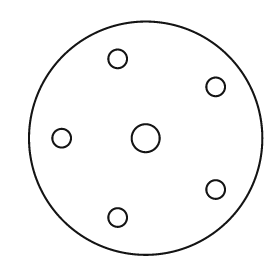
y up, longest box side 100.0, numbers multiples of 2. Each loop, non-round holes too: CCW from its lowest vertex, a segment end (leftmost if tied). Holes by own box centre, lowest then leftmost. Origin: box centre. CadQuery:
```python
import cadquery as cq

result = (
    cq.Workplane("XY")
    .moveTo(0.0, 0.0)
    .circle(50.0)
    .moveTo(-12.0, -34.0)
    .circle(4.0)
    .moveTo(30.0, -22.0)
    .circle(4.0)
    .moveTo(-36.0, 0.0)
    .circle(4.0)
    .moveTo(0.0, 0.0)
    .circle(6.0)
    .moveTo(30.0, 22.0)
    .circle(4.0)
    .moveTo(-12.0, 34.0)
    .circle(4.0)
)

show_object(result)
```